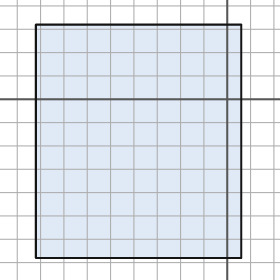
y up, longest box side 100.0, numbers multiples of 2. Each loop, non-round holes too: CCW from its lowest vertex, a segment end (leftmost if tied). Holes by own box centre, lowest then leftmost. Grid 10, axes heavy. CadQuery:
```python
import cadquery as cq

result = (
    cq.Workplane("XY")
    .moveTo(-82.0, -68.0)
    .lineTo(6.0, -68.0)
    .lineTo(6.0, 32.0)
    .lineTo(-82.0, 32.0)
    .close()
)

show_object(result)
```